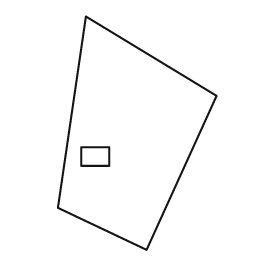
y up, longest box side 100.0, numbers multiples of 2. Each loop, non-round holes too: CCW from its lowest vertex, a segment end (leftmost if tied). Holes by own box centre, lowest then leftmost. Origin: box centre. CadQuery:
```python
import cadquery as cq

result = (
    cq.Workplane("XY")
    .moveTo(4.0, -50.0)
    .lineTo(34.0, 16.0)
    .lineTo(-22.0, 50.0)
    .lineTo(-34.0, -32.0)
    .close()
    .moveTo(-24.0, -14.0)
    .lineTo(-12.0, -14.0)
    .lineTo(-12.0, -6.0)
    .lineTo(-24.0, -6.0)
    .close()
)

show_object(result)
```